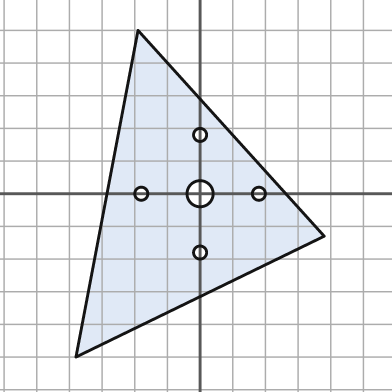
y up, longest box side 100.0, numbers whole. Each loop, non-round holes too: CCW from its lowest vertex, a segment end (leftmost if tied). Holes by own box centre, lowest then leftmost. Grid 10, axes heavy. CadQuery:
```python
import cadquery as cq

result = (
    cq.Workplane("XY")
    .moveTo(-38.0, -50.0)
    .lineTo(38.0, -13.0)
    .lineTo(-19.0, 50.0)
    .close()
    .moveTo(0.0, -18.0)
    .circle(2.0)
    .moveTo(-18.0, 0.0)
    .circle(2.0)
    .moveTo(0.0, 0.0)
    .circle(4.0)
    .moveTo(18.0, 0.0)
    .circle(2.0)
    .moveTo(0.0, 18.0)
    .circle(2.0)
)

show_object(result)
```